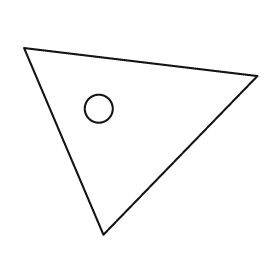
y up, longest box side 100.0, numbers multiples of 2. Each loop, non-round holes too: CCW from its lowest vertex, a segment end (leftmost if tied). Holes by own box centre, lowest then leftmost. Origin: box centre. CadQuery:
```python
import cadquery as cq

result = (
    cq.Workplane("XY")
    .moveTo(-16.0, -40.0)
    .lineTo(50.0, 28.0)
    .lineTo(-50.0, 40.0)
    .close()
    .moveTo(-18.0, 14.0)
    .circle(6.0)
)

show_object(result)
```